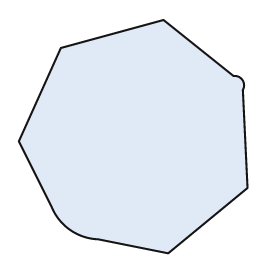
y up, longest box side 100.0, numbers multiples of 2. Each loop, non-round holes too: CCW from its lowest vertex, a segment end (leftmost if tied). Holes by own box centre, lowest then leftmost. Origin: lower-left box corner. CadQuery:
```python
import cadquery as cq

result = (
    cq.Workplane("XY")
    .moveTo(64.0, 0.0)
    .lineTo(98.0, 28.0)
    .lineTo(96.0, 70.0)
    .threePointArc((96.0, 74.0), (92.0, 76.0))
    .lineTo(62.0, 100.0)
    .lineTo(18.0, 88.0)
    .lineTo(0.0, 48.0)
    .lineTo(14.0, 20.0)
    .threePointArc((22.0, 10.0), (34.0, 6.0))
    .close()
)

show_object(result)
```